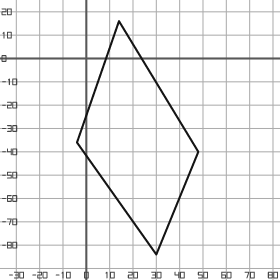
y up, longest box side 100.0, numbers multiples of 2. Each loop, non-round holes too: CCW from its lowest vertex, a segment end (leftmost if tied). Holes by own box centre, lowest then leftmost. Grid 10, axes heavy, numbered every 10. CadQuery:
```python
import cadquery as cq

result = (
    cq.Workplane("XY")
    .moveTo(30.0, -84.0)
    .lineTo(48.0, -40.0)
    .lineTo(14.0, 16.0)
    .lineTo(-4.0, -36.0)
    .close()
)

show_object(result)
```